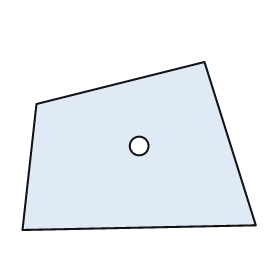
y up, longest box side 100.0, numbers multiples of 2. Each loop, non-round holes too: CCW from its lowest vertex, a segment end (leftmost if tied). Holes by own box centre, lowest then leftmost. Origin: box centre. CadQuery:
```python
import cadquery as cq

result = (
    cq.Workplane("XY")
    .moveTo(-50.0, -36.0)
    .lineTo(50.0, -34.0)
    .lineTo(28.0, 36.0)
    .lineTo(-44.0, 18.0)
    .close()
    .moveTo(0.0, 0.0)
    .circle(4.0)
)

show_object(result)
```